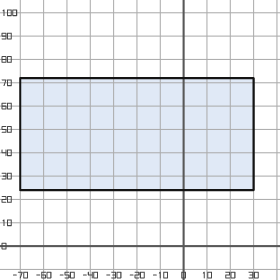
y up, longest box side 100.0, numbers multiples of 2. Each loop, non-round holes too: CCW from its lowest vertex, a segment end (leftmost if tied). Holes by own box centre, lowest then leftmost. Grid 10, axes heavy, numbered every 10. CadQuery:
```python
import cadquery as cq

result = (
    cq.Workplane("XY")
    .moveTo(-70.0, 24.0)
    .lineTo(30.0, 24.0)
    .lineTo(30.0, 72.0)
    .lineTo(-70.0, 72.0)
    .close()
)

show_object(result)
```